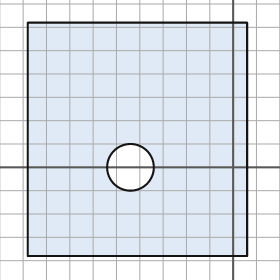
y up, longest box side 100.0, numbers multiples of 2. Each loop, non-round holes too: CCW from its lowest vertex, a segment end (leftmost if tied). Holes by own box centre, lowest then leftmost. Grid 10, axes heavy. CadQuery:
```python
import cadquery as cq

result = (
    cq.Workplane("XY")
    .moveTo(-88.0, -38.0)
    .lineTo(6.0, -38.0)
    .lineTo(6.0, 62.0)
    .lineTo(-88.0, 62.0)
    .close()
    .moveTo(-44.0, 0.0)
    .circle(10.0)
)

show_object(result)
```